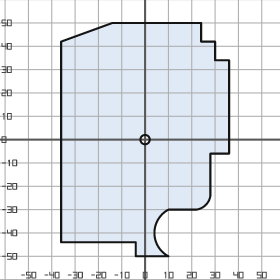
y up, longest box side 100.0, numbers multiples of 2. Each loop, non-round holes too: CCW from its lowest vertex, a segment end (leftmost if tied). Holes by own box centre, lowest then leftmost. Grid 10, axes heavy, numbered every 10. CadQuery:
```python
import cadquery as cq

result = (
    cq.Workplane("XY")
    .moveTo(-4.0, -50.0)
    .lineTo(10.0, -50.0)
    .threePointArc((4.0, -40.0), (10.0, -30.0))
    .lineTo(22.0, -30.0)
    .threePointArc((26.0, -28.0), (28.0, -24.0))
    .lineTo(28.0, -6.0)
    .lineTo(36.0, -6.0)
    .lineTo(36.0, 34.0)
    .lineTo(30.0, 34.0)
    .lineTo(30.0, 42.0)
    .lineTo(24.0, 42.0)
    .lineTo(24.0, 50.0)
    .lineTo(-14.0, 50.0)
    .lineTo(-36.0, 42.0)
    .lineTo(-36.0, -44.0)
    .lineTo(-4.0, -44.0)
    .close()
    .moveTo(0.0, 0.0)
    .circle(2.0)
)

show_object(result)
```